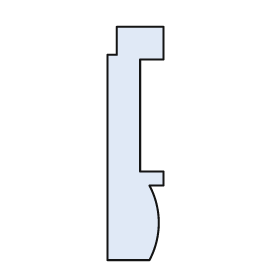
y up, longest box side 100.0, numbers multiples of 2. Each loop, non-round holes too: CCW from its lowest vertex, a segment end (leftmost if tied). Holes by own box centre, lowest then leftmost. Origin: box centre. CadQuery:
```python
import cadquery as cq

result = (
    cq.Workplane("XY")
    .moveTo(-12.0, -50.0)
    .lineTo(6.0, -50.0)
    .threePointArc((10.0, -34.0), (6.0, -18.0))
    .lineTo(12.0, -18.0)
    .lineTo(12.0, -12.0)
    .lineTo(2.0, -12.0)
    .lineTo(2.0, 36.0)
    .lineTo(12.0, 36.0)
    .lineTo(12.0, 50.0)
    .lineTo(-8.0, 50.0)
    .lineTo(-8.0, 38.0)
    .lineTo(-12.0, 38.0)
    .close()
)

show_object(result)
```